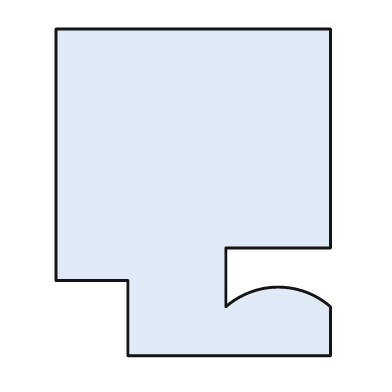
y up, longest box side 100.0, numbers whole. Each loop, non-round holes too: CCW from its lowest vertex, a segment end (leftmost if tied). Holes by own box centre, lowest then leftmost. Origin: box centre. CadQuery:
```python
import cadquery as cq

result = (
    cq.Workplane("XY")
    .moveTo(-20.0, -50.0)
    .lineTo(42.0, -50.0)
    .lineTo(42.0, -35.0)
    .threePointArc((26.0, -29.0), (10.0, -35.0))
    .lineTo(10.0, -17.0)
    .lineTo(42.0, -17.0)
    .lineTo(42.0, 50.0)
    .lineTo(-42.0, 50.0)
    .lineTo(-42.0, -27.0)
    .lineTo(-20.0, -27.0)
    .close()
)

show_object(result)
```